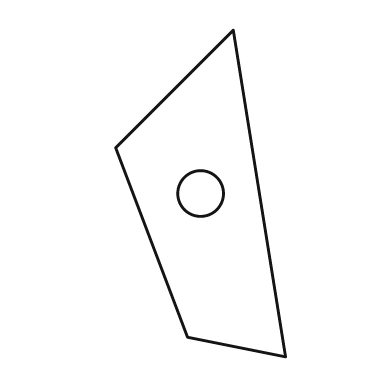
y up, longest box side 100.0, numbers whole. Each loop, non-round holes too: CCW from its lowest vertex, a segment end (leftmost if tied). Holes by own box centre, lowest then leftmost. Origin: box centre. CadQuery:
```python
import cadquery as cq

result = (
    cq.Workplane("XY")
    .moveTo(26.0, -50.0)
    .lineTo(10.0, 50.0)
    .lineTo(-26.0, 14.0)
    .lineTo(-4.0, -44.0)
    .close()
    .moveTo(0.0, 0.0)
    .circle(7.0)
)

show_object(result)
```